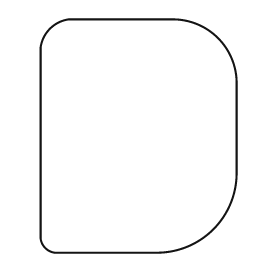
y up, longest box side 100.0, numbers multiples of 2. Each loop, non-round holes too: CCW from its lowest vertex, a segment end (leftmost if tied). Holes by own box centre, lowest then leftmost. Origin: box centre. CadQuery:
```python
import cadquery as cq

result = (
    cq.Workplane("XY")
    .moveTo(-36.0, -50.0)
    .lineTo(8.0, -50.0)
    .threePointArc((32.0, -40.0), (42.0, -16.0))
    .lineTo(42.0, 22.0)
    .threePointArc((34.0, 42.0), (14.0, 50.0))
    .lineTo(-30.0, 50.0)
    .threePointArc((-38.0, 46.0), (-42.0, 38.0))
    .lineTo(-42.0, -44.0)
    .threePointArc((-40.0, -48.0), (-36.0, -50.0))
    .close()
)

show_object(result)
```